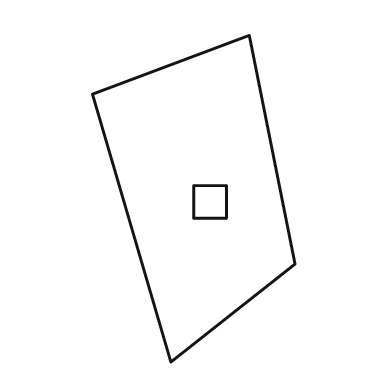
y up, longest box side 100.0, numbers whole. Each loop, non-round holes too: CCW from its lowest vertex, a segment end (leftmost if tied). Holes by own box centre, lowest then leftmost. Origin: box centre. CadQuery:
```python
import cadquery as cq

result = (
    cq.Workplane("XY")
    .moveTo(-7.0, -50.0)
    .lineTo(31.0, -20.0)
    .lineTo(17.0, 50.0)
    .lineTo(-31.0, 32.0)
    .close()
    .moveTo(0.0, -6.0)
    .lineTo(10.0, -6.0)
    .lineTo(10.0, 4.0)
    .lineTo(0.0, 4.0)
    .close()
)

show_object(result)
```